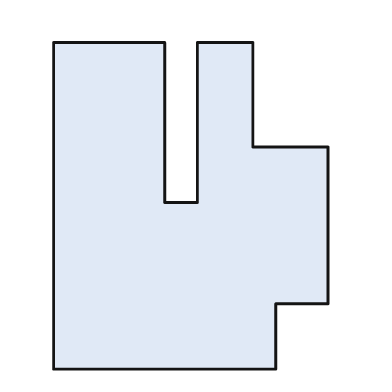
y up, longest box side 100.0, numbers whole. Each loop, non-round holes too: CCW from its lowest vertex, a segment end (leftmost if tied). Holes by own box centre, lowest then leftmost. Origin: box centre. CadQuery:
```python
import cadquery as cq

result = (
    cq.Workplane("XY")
    .moveTo(-42.0, -50.0)
    .lineTo(26.0, -50.0)
    .lineTo(26.0, -30.0)
    .lineTo(42.0, -30.0)
    .lineTo(42.0, 18.0)
    .lineTo(19.0, 18.0)
    .lineTo(19.0, 50.0)
    .lineTo(2.0, 50.0)
    .lineTo(2.0, 1.0)
    .lineTo(-8.0, 1.0)
    .lineTo(-8.0, 50.0)
    .lineTo(-42.0, 50.0)
    .close()
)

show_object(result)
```